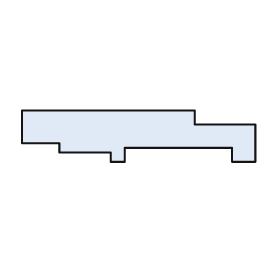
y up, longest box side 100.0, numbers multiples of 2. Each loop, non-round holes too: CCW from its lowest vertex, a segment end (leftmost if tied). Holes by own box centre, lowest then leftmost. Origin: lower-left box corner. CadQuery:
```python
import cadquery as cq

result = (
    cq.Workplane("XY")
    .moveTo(38.0, 0.0)
    .lineTo(44.0, 0.0)
    .lineTo(44.0, 6.0)
    .lineTo(90.0, 6.0)
    .lineTo(90.0, 0.0)
    .lineTo(100.0, 0.0)
    .lineTo(100.0, 16.0)
    .lineTo(74.0, 16.0)
    .lineTo(74.0, 22.0)
    .lineTo(0.0, 22.0)
    .lineTo(0.0, 8.0)
    .lineTo(16.0, 8.0)
    .lineTo(16.0, 4.0)
    .lineTo(38.0, 4.0)
    .close()
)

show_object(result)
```